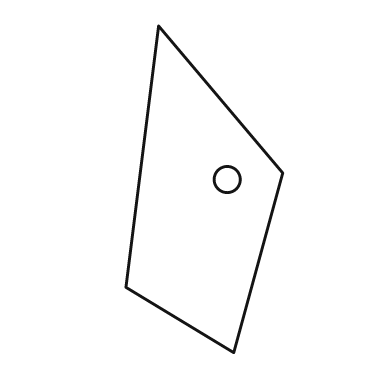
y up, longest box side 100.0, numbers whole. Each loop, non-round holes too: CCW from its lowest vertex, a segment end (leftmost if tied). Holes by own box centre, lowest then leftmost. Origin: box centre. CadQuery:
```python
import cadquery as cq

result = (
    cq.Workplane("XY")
    .moveTo(9.0, -50.0)
    .lineTo(24.0, 5.0)
    .lineTo(-14.0, 50.0)
    .lineTo(-24.0, -30.0)
    .close()
    .moveTo(7.0, 3.0)
    .circle(4.0)
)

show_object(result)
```